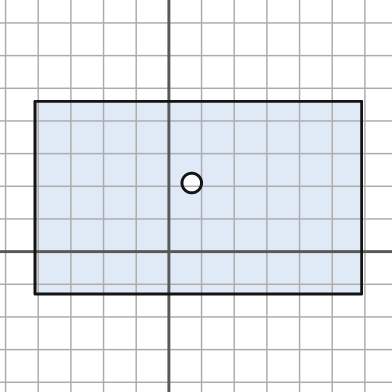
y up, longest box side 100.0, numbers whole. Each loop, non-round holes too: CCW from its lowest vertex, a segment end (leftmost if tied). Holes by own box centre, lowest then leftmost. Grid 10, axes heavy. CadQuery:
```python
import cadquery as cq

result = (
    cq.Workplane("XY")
    .moveTo(-41.0, -13.0)
    .lineTo(59.0, -13.0)
    .lineTo(59.0, 46.0)
    .lineTo(-41.0, 46.0)
    .close()
    .moveTo(7.0, 21.0)
    .circle(3.0)
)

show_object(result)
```